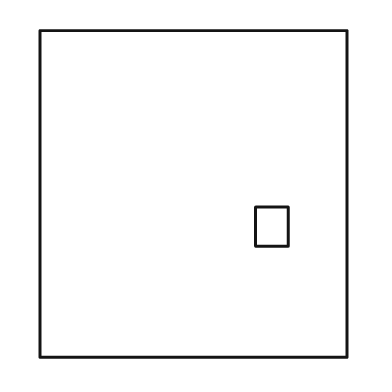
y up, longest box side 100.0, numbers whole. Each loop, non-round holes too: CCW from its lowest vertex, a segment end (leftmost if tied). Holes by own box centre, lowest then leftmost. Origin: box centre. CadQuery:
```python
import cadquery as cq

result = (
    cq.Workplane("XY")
    .moveTo(-47.0, -50.0)
    .lineTo(47.0, -50.0)
    .lineTo(47.0, 50.0)
    .lineTo(-47.0, 50.0)
    .close()
    .moveTo(19.0, -16.0)
    .lineTo(29.0, -16.0)
    .lineTo(29.0, -4.0)
    .lineTo(19.0, -4.0)
    .close()
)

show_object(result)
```